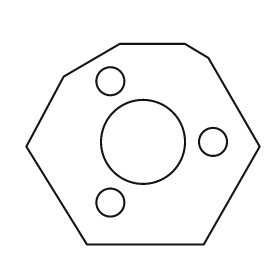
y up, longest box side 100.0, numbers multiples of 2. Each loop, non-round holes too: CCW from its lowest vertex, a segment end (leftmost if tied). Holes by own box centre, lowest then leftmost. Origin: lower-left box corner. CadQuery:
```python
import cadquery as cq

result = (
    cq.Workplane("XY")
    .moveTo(26.0, 0.0)
    .lineTo(76.0, 0.0)
    .lineTo(100.0, 42.0)
    .lineTo(78.0, 80.0)
    .lineTo(68.0, 86.0)
    .lineTo(40.0, 86.0)
    .lineTo(16.0, 72.0)
    .lineTo(0.0, 42.0)
    .close()
    .moveTo(36.0, 18.0)
    .circle(6.0)
    .moveTo(50.0, 44.0)
    .circle(18.0)
    .moveTo(80.0, 44.0)
    .circle(6.0)
    .moveTo(36.0, 70.0)
    .circle(6.0)
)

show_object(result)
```